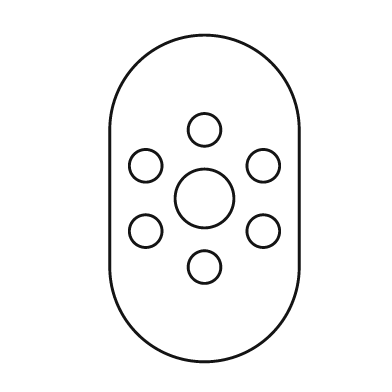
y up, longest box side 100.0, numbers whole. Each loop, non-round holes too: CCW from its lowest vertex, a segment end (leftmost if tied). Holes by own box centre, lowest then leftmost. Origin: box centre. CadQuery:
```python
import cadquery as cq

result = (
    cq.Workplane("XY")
    .moveTo(-29.0, -21.0)
    .threePointArc((0.0, -50.0), (29.0, -21.0))
    .lineTo(29.0, 21.0)
    .threePointArc((0.0, 50.0), (-29.0, 21.0))
    .close()
    .moveTo(0.0, -21.0)
    .circle(5.0)
    .moveTo(-18.0, -10.0)
    .circle(5.0)
    .moveTo(18.0, -10.0)
    .circle(5.0)
    .moveTo(0.0, 0.0)
    .circle(9.0)
    .moveTo(-18.0, 10.0)
    .circle(5.0)
    .moveTo(18.0, 10.0)
    .circle(5.0)
    .moveTo(0.0, 21.0)
    .circle(5.0)
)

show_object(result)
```